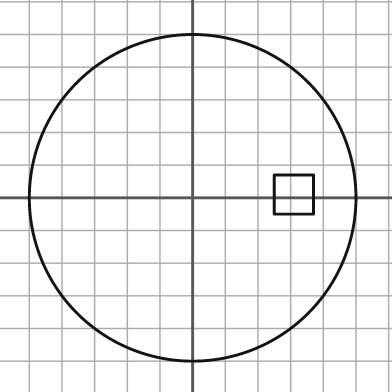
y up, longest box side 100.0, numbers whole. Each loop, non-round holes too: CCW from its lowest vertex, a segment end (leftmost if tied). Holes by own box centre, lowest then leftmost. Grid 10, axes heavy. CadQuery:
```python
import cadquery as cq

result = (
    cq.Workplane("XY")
    .moveTo(0.0, 0.0)
    .circle(50.0)
    .moveTo(25.0, -5.0)
    .lineTo(37.0, -5.0)
    .lineTo(37.0, 7.0)
    .lineTo(25.0, 7.0)
    .close()
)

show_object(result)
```